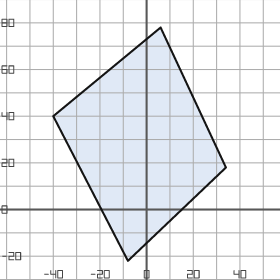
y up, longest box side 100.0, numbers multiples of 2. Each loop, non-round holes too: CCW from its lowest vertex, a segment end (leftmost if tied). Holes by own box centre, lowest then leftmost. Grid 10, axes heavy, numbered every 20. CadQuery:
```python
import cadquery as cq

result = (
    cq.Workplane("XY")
    .moveTo(-8.0, -22.0)
    .lineTo(34.0, 18.0)
    .lineTo(6.0, 78.0)
    .lineTo(-40.0, 40.0)
    .close()
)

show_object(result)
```